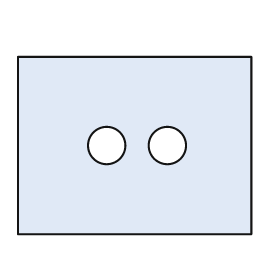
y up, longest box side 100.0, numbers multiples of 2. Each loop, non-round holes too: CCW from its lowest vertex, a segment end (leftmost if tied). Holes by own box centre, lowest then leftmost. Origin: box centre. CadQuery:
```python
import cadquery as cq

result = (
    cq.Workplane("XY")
    .moveTo(-50.0, -38.0)
    .lineTo(50.0, -38.0)
    .lineTo(50.0, 38.0)
    .lineTo(-50.0, 38.0)
    .close()
    .moveTo(-12.0, 0.0)
    .circle(8.0)
    .moveTo(14.0, 0.0)
    .circle(8.0)
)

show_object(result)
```